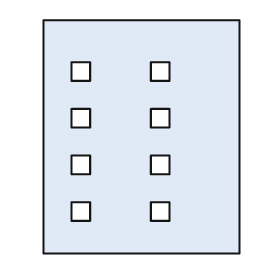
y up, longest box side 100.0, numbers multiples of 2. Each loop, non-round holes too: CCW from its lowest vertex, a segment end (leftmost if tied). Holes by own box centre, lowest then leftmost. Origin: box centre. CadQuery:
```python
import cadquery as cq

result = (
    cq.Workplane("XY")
    .moveTo(-42.0, -50.0)
    .lineTo(42.0, -50.0)
    .lineTo(42.0, 50.0)
    .lineTo(-42.0, 50.0)
    .close()
    .moveTo(-30.0, -36.0)
    .lineTo(-22.0, -36.0)
    .lineTo(-22.0, -28.0)
    .lineTo(-30.0, -28.0)
    .close()
    .moveTo(4.0, -36.0)
    .lineTo(12.0, -36.0)
    .lineTo(12.0, -28.0)
    .lineTo(4.0, -28.0)
    .close()
    .moveTo(-30.0, -16.0)
    .lineTo(-22.0, -16.0)
    .lineTo(-22.0, -8.0)
    .lineTo(-30.0, -8.0)
    .close()
    .moveTo(4.0, -16.0)
    .lineTo(12.0, -16.0)
    .lineTo(12.0, -8.0)
    .lineTo(4.0, -8.0)
    .close()
    .moveTo(-30.0, 4.0)
    .lineTo(-22.0, 4.0)
    .lineTo(-22.0, 12.0)
    .lineTo(-30.0, 12.0)
    .close()
    .moveTo(4.0, 4.0)
    .lineTo(12.0, 4.0)
    .lineTo(12.0, 12.0)
    .lineTo(4.0, 12.0)
    .close()
    .moveTo(-30.0, 24.0)
    .lineTo(-22.0, 24.0)
    .lineTo(-22.0, 32.0)
    .lineTo(-30.0, 32.0)
    .close()
    .moveTo(4.0, 24.0)
    .lineTo(12.0, 24.0)
    .lineTo(12.0, 32.0)
    .lineTo(4.0, 32.0)
    .close()
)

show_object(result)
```